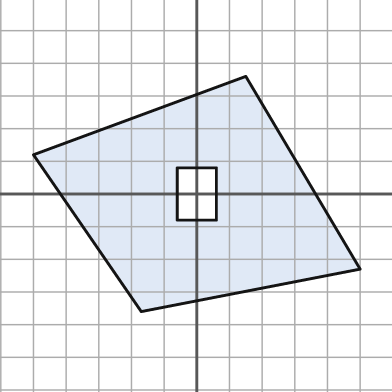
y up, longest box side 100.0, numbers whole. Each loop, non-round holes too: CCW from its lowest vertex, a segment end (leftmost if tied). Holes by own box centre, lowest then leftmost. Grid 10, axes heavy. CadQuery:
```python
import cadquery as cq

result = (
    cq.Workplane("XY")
    .moveTo(-17.0, -36.0)
    .lineTo(50.0, -23.0)
    .lineTo(15.0, 36.0)
    .lineTo(-50.0, 12.0)
    .close()
    .moveTo(-6.0, -8.0)
    .lineTo(6.0, -8.0)
    .lineTo(6.0, 8.0)
    .lineTo(-6.0, 8.0)
    .close()
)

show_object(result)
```